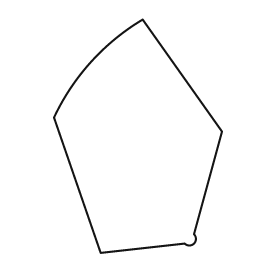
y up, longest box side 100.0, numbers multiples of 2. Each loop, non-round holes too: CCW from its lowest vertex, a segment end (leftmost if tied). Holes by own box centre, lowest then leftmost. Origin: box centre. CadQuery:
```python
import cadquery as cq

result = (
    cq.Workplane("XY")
    .moveTo(-16.0, -50.0)
    .lineTo(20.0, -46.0)
    .threePointArc((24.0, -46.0), (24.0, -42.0))
    .lineTo(36.0, 2.0)
    .lineTo(2.0, 50.0)
    .threePointArc((-20.0, 32.0), (-36.0, 8.0))
    .close()
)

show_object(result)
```